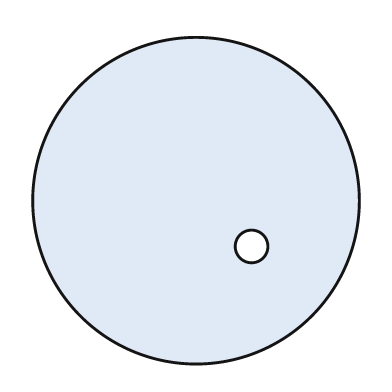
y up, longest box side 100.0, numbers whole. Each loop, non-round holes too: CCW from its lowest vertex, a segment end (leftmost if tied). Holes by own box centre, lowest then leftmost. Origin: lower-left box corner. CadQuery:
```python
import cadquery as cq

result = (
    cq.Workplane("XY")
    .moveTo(50.0, 50.0)
    .circle(50.0)
    .moveTo(67.0, 36.0)
    .circle(5.0)
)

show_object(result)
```